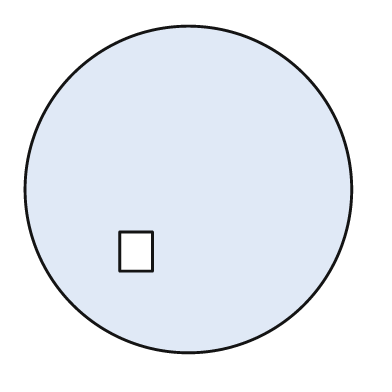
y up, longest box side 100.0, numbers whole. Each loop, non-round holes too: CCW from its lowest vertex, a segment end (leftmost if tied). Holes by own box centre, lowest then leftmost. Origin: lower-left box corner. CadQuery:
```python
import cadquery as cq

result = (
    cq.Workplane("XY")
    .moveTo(50.0, 50.0)
    .circle(50.0)
    .moveTo(29.0, 25.0)
    .lineTo(39.0, 25.0)
    .lineTo(39.0, 37.0)
    .lineTo(29.0, 37.0)
    .close()
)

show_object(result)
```